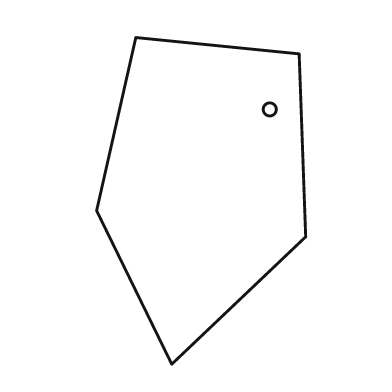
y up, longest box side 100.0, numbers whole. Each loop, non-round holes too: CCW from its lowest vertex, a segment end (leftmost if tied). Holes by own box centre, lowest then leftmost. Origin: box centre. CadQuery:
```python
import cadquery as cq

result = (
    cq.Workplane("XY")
    .moveTo(-9.0, -50.0)
    .lineTo(32.0, -11.0)
    .lineTo(30.0, 45.0)
    .lineTo(-20.0, 50.0)
    .lineTo(-32.0, -3.0)
    .close()
    .moveTo(21.0, 28.0)
    .circle(2.0)
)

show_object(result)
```